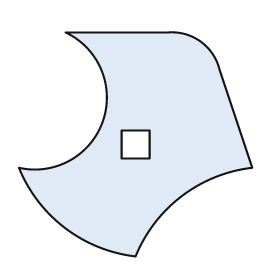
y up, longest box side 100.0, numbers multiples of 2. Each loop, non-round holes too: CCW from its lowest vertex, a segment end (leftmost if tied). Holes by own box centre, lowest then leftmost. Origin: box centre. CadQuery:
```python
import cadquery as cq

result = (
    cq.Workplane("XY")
    .moveTo(0.0, -48.0)
    .threePointArc((20.0, -22.0), (50.0, -10.0))
    .lineTo(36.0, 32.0)
    .threePointArc((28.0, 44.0), (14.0, 48.0))
    .lineTo(-30.0, 48.0)
    .threePointArc((-14.0, 10.0), (-50.0, -10.0))
    .threePointArc((-30.0, -36.0), (0.0, -48.0))
    .close()
    .moveTo(-6.0, -6.0)
    .lineTo(6.0, -6.0)
    .lineTo(6.0, 6.0)
    .lineTo(-6.0, 6.0)
    .close()
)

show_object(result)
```